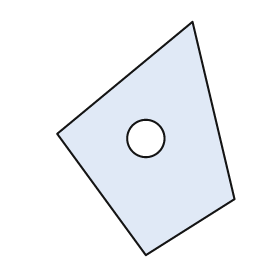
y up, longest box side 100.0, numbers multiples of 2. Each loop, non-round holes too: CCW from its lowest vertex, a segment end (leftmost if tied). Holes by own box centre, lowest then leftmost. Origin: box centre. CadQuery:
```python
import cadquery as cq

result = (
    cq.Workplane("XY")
    .moveTo(0.0, -50.0)
    .lineTo(38.0, -26.0)
    .lineTo(20.0, 50.0)
    .lineTo(-38.0, 2.0)
    .close()
    .moveTo(0.0, 0.0)
    .circle(8.0)
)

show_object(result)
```